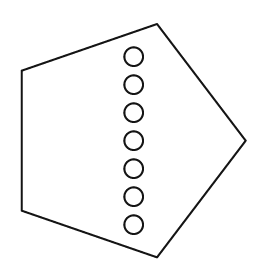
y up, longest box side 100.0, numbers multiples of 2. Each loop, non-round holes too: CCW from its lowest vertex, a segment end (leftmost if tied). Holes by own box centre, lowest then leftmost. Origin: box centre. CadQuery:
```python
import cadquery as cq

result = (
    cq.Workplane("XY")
    .moveTo(10.0, -50.0)
    .lineTo(48.0, 0.0)
    .lineTo(10.0, 50.0)
    .lineTo(-48.0, 30.0)
    .lineTo(-48.0, -30.0)
    .close()
    .moveTo(0.0, -36.0)
    .circle(4.0)
    .moveTo(0.0, -24.0)
    .circle(4.0)
    .moveTo(0.0, -12.0)
    .circle(4.0)
    .moveTo(0.0, 0.0)
    .circle(4.0)
    .moveTo(0.0, 12.0)
    .circle(4.0)
    .moveTo(0.0, 24.0)
    .circle(4.0)
    .moveTo(0.0, 36.0)
    .circle(4.0)
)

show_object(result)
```